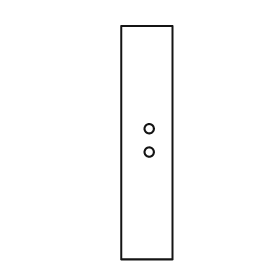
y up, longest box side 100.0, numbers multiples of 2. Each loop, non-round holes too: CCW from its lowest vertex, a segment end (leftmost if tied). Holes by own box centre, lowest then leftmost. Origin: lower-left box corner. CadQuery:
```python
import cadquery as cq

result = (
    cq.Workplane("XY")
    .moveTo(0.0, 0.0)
    .lineTo(22.0, 0.0)
    .lineTo(22.0, 100.0)
    .lineTo(0.0, 100.0)
    .close()
    .moveTo(12.0, 46.0)
    .circle(2.0)
    .moveTo(12.0, 56.0)
    .circle(2.0)
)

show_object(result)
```